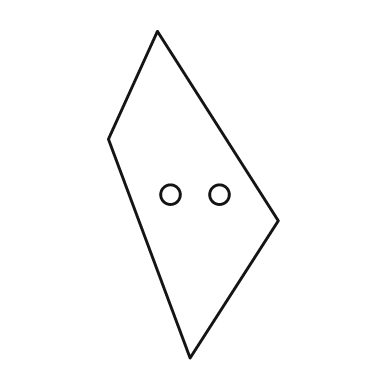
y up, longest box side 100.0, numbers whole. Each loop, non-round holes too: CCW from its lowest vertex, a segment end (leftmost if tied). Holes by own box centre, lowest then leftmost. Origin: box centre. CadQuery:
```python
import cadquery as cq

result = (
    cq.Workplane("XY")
    .moveTo(-1.0, -50.0)
    .lineTo(26.0, -8.0)
    .lineTo(-11.0, 50.0)
    .lineTo(-26.0, 17.0)
    .close()
    .moveTo(-7.0, 0.0)
    .circle(3.0)
    .moveTo(8.0, 0.0)
    .circle(3.0)
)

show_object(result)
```